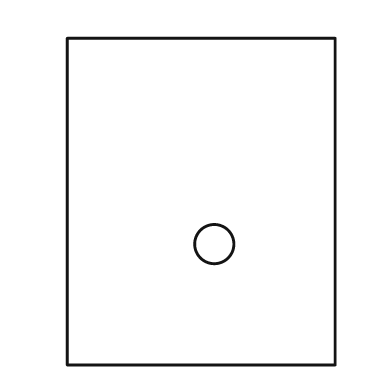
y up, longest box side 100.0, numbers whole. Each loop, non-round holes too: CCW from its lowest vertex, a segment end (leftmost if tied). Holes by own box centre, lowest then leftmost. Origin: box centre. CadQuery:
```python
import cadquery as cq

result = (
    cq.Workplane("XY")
    .moveTo(-41.0, -50.0)
    .lineTo(41.0, -50.0)
    .lineTo(41.0, 50.0)
    .lineTo(-41.0, 50.0)
    .close()
    .moveTo(4.0, -13.0)
    .circle(6.0)
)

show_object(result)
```